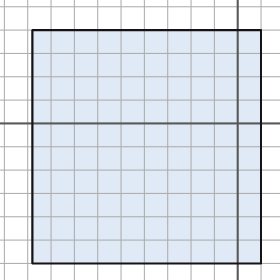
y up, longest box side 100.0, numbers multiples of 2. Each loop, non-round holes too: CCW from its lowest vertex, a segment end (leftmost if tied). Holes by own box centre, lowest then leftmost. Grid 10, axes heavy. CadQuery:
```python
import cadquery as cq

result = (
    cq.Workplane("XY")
    .moveTo(-88.0, -60.0)
    .lineTo(10.0, -60.0)
    .lineTo(10.0, 40.0)
    .lineTo(-88.0, 40.0)
    .close()
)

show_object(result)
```